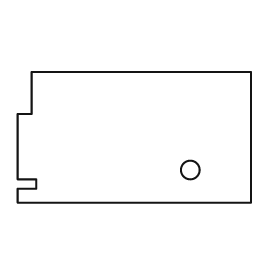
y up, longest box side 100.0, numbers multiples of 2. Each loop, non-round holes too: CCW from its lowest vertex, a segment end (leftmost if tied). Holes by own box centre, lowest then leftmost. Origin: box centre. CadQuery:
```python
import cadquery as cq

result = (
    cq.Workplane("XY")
    .moveTo(-50.0, -28.0)
    .lineTo(50.0, -28.0)
    .lineTo(50.0, 28.0)
    .lineTo(-44.0, 28.0)
    .lineTo(-44.0, 10.0)
    .lineTo(-50.0, 10.0)
    .lineTo(-50.0, -18.0)
    .lineTo(-42.0, -18.0)
    .lineTo(-42.0, -22.0)
    .lineTo(-50.0, -22.0)
    .close()
    .moveTo(24.0, -14.0)
    .circle(4.0)
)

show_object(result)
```